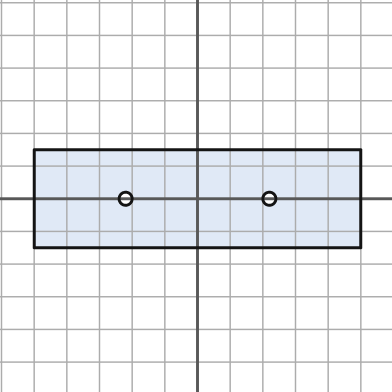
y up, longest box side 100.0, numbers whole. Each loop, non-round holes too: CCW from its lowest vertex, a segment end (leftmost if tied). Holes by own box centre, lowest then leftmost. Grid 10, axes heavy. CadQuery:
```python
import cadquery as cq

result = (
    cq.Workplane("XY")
    .moveTo(-50.0, -15.0)
    .lineTo(50.0, -15.0)
    .lineTo(50.0, 15.0)
    .lineTo(-50.0, 15.0)
    .close()
    .moveTo(-22.0, 0.0)
    .circle(2.0)
    .moveTo(22.0, 0.0)
    .circle(2.0)
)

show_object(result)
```